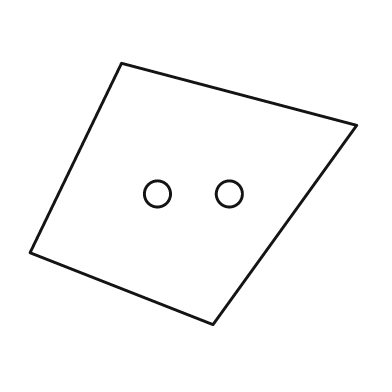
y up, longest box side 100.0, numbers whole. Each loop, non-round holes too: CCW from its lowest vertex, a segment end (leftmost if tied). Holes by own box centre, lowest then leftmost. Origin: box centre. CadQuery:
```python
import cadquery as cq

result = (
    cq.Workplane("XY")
    .moveTo(6.0, -40.0)
    .lineTo(50.0, 21.0)
    .lineTo(-22.0, 40.0)
    .lineTo(-50.0, -18.0)
    .close()
    .moveTo(-11.0, 0.0)
    .circle(4.0)
    .moveTo(11.0, 0.0)
    .circle(4.0)
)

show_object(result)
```